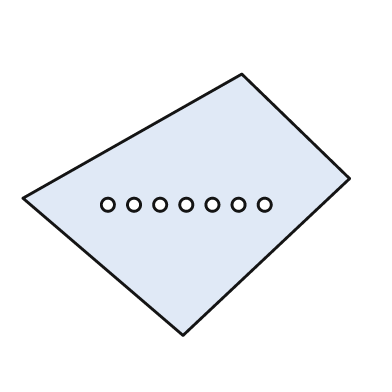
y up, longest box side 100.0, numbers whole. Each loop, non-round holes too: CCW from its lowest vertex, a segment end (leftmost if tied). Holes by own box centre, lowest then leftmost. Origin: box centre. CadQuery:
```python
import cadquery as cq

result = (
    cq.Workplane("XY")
    .moveTo(-1.0, -40.0)
    .lineTo(50.0, 8.0)
    .lineTo(17.0, 40.0)
    .lineTo(-50.0, 2.0)
    .close()
    .moveTo(-24.0, 0.0)
    .circle(2.0)
    .moveTo(-16.0, 0.0)
    .circle(2.0)
    .moveTo(-8.0, 0.0)
    .circle(2.0)
    .moveTo(0.0, 0.0)
    .circle(2.0)
    .moveTo(8.0, 0.0)
    .circle(2.0)
    .moveTo(16.0, 0.0)
    .circle(2.0)
    .moveTo(24.0, 0.0)
    .circle(2.0)
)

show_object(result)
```